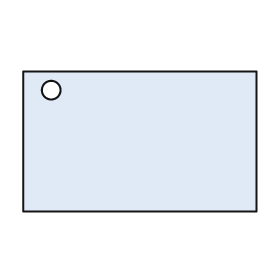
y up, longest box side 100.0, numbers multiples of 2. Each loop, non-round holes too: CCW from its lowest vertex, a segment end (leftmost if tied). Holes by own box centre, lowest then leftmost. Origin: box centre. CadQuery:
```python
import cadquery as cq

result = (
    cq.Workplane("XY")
    .moveTo(-50.0, -30.0)
    .lineTo(50.0, -30.0)
    .lineTo(50.0, 30.0)
    .lineTo(-50.0, 30.0)
    .close()
    .moveTo(-38.0, 22.0)
    .circle(4.0)
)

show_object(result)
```